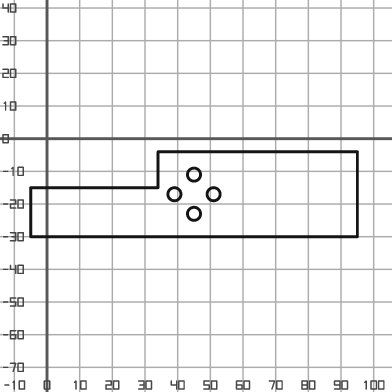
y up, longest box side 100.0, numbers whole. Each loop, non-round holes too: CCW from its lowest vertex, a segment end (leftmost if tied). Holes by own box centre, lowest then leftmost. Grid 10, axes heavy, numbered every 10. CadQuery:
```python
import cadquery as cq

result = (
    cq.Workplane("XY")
    .moveTo(-5.0, -30.0)
    .lineTo(95.0, -30.0)
    .lineTo(95.0, -4.0)
    .lineTo(34.0, -4.0)
    .lineTo(34.0, -15.0)
    .lineTo(-5.0, -15.0)
    .close()
    .moveTo(45.0, -23.0)
    .circle(2.0)
    .moveTo(39.0, -17.0)
    .circle(2.0)
    .moveTo(51.0, -17.0)
    .circle(2.0)
    .moveTo(45.0, -11.0)
    .circle(2.0)
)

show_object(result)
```